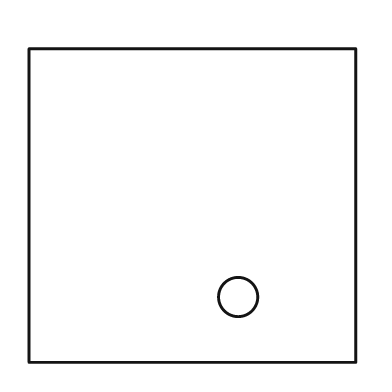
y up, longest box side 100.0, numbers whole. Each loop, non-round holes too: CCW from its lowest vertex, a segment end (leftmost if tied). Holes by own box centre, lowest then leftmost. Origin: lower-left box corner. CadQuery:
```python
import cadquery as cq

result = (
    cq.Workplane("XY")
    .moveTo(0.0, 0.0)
    .lineTo(100.0, 0.0)
    .lineTo(100.0, 96.0)
    .lineTo(0.0, 96.0)
    .close()
    .moveTo(64.0, 20.0)
    .circle(6.0)
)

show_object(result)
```